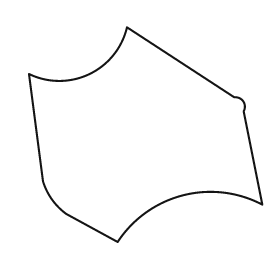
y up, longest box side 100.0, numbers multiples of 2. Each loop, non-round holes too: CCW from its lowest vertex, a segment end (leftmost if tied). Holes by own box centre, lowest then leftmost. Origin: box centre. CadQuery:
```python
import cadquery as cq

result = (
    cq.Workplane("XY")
    .moveTo(-12.0, -46.0)
    .threePointArc((16.0, -26.0), (50.0, -30.0))
    .lineTo(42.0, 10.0)
    .threePointArc((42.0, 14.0), (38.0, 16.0))
    .lineTo(-8.0, 46.0)
    .threePointArc((-24.0, 26.0), (-50.0, 26.0))
    .lineTo(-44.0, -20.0)
    .threePointArc((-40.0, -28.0), (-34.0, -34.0))
    .close()
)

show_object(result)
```